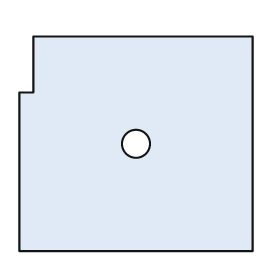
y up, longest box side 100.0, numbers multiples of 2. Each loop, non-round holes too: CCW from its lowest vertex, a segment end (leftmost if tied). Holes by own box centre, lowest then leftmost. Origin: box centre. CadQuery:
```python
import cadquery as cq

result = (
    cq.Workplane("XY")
    .moveTo(-50.0, -46.0)
    .lineTo(50.0, -46.0)
    .lineTo(50.0, 46.0)
    .lineTo(-44.0, 46.0)
    .lineTo(-44.0, 22.0)
    .lineTo(-50.0, 22.0)
    .close()
    .moveTo(0.0, 0.0)
    .circle(6.0)
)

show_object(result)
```